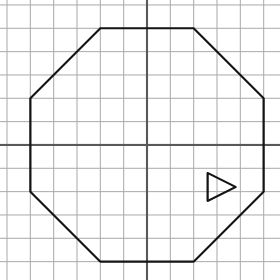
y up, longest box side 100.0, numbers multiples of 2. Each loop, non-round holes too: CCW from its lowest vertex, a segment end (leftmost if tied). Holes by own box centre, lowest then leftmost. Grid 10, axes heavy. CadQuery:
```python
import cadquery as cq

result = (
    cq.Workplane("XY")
    .moveTo(-20.0, -50.0)
    .lineTo(20.0, -50.0)
    .lineTo(50.0, -20.0)
    .lineTo(50.0, 20.0)
    .lineTo(20.0, 50.0)
    .lineTo(-20.0, 50.0)
    .lineTo(-50.0, 20.0)
    .lineTo(-50.0, -20.0)
    .close()
    .moveTo(26.0, -24.0)
    .lineTo(38.0, -18.0)
    .lineTo(26.0, -12.0)
    .close()
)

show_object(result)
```